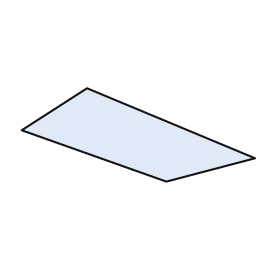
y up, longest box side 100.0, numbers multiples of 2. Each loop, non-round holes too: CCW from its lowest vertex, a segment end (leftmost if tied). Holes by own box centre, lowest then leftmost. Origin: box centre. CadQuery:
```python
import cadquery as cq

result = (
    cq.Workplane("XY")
    .moveTo(12.0, -20.0)
    .lineTo(50.0, -10.0)
    .lineTo(-22.0, 20.0)
    .lineTo(-50.0, 2.0)
    .close()
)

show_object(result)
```